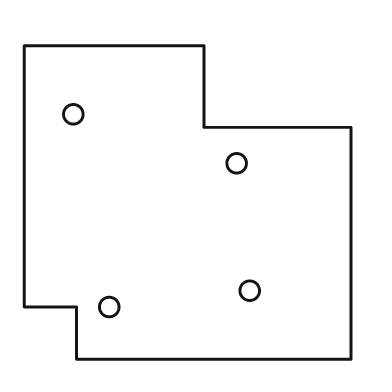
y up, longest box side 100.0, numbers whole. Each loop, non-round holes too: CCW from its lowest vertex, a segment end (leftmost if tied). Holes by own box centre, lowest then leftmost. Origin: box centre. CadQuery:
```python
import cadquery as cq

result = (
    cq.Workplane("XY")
    .moveTo(-34.0, -48.0)
    .lineTo(50.0, -48.0)
    .lineTo(50.0, 23.0)
    .lineTo(5.0, 23.0)
    .lineTo(5.0, 48.0)
    .lineTo(-50.0, 48.0)
    .lineTo(-50.0, -32.0)
    .lineTo(-34.0, -32.0)
    .close()
    .moveTo(-24.0, -32.0)
    .circle(3.0)
    .moveTo(19.0, -27.0)
    .circle(3.0)
    .moveTo(15.0, 12.0)
    .circle(3.0)
    .moveTo(-35.0, 27.0)
    .circle(3.0)
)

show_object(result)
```